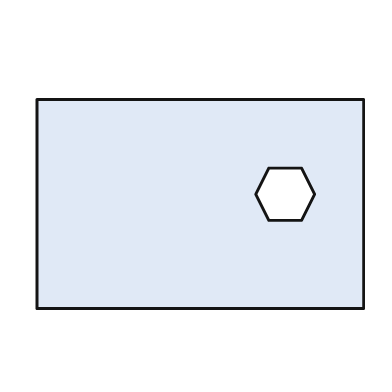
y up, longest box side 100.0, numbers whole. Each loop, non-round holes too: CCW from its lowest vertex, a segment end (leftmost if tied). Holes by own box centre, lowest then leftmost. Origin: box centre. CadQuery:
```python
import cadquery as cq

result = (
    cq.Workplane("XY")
    .moveTo(-50.0, -32.0)
    .lineTo(50.0, -32.0)
    .lineTo(50.0, 32.0)
    .lineTo(-50.0, 32.0)
    .close()
    .moveTo(21.0, -5.0)
    .lineTo(31.0, -5.0)
    .lineTo(35.0, 3.0)
    .lineTo(31.0, 11.0)
    .lineTo(21.0, 11.0)
    .lineTo(17.0, 3.0)
    .close()
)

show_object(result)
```